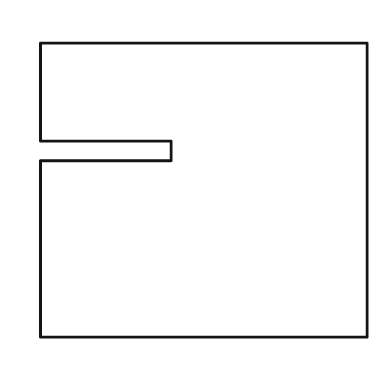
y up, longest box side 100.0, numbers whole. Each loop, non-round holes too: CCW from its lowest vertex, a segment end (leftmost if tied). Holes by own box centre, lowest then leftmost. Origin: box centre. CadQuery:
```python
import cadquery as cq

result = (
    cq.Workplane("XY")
    .moveTo(-50.0, -45.0)
    .lineTo(50.0, -45.0)
    .lineTo(50.0, 45.0)
    .lineTo(-50.0, 45.0)
    .lineTo(-50.0, 15.0)
    .lineTo(-10.0, 15.0)
    .lineTo(-10.0, 9.0)
    .lineTo(-50.0, 9.0)
    .close()
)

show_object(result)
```